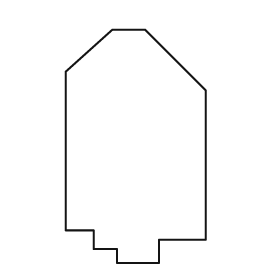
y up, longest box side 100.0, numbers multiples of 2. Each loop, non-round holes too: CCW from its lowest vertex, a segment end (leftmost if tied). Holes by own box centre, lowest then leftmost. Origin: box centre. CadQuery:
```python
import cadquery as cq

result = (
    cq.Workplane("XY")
    .moveTo(-8.0, -50.0)
    .lineTo(10.0, -50.0)
    .lineTo(10.0, -40.0)
    .lineTo(30.0, -40.0)
    .lineTo(30.0, 24.0)
    .lineTo(4.0, 50.0)
    .lineTo(-10.0, 50.0)
    .lineTo(-30.0, 32.0)
    .lineTo(-30.0, -36.0)
    .lineTo(-18.0, -36.0)
    .lineTo(-18.0, -44.0)
    .lineTo(-8.0, -44.0)
    .close()
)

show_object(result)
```